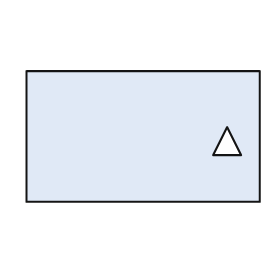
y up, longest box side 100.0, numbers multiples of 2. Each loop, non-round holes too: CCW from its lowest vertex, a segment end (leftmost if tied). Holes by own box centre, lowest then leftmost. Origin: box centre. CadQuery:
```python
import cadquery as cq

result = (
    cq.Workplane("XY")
    .moveTo(-50.0, -28.0)
    .lineTo(50.0, -28.0)
    .lineTo(50.0, 28.0)
    .lineTo(-50.0, 28.0)
    .close()
    .moveTo(30.0, -8.0)
    .lineTo(42.0, -8.0)
    .lineTo(36.0, 4.0)
    .close()
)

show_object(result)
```